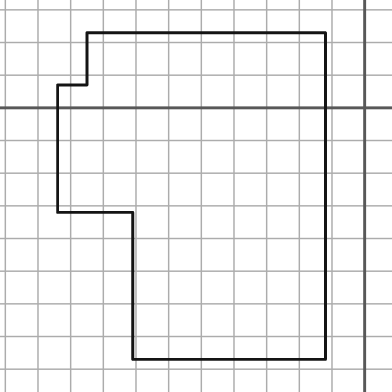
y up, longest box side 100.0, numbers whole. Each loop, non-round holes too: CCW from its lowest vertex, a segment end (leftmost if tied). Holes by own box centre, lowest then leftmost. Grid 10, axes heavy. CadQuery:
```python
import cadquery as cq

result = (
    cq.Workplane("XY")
    .moveTo(-71.0, -77.0)
    .lineTo(-12.0, -77.0)
    .lineTo(-12.0, 23.0)
    .lineTo(-85.0, 23.0)
    .lineTo(-85.0, 7.0)
    .lineTo(-94.0, 7.0)
    .lineTo(-94.0, -32.0)
    .lineTo(-71.0, -32.0)
    .close()
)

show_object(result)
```